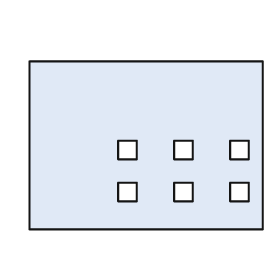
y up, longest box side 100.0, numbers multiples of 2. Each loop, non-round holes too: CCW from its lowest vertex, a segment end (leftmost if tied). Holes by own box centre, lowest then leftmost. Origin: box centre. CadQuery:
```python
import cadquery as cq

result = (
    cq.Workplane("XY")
    .moveTo(-50.0, -36.0)
    .lineTo(50.0, -36.0)
    .lineTo(50.0, 36.0)
    .lineTo(-50.0, 36.0)
    .close()
    .moveTo(-12.0, -24.0)
    .lineTo(-4.0, -24.0)
    .lineTo(-4.0, -16.0)
    .lineTo(-12.0, -16.0)
    .close()
    .moveTo(12.0, -24.0)
    .lineTo(20.0, -24.0)
    .lineTo(20.0, -16.0)
    .lineTo(12.0, -16.0)
    .close()
    .moveTo(36.0, -24.0)
    .lineTo(44.0, -24.0)
    .lineTo(44.0, -16.0)
    .lineTo(36.0, -16.0)
    .close()
    .moveTo(-12.0, -6.0)
    .lineTo(-4.0, -6.0)
    .lineTo(-4.0, 2.0)
    .lineTo(-12.0, 2.0)
    .close()
    .moveTo(12.0, -6.0)
    .lineTo(20.0, -6.0)
    .lineTo(20.0, 2.0)
    .lineTo(12.0, 2.0)
    .close()
    .moveTo(36.0, -6.0)
    .lineTo(44.0, -6.0)
    .lineTo(44.0, 2.0)
    .lineTo(36.0, 2.0)
    .close()
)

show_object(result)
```